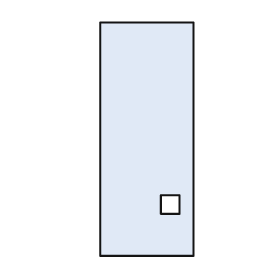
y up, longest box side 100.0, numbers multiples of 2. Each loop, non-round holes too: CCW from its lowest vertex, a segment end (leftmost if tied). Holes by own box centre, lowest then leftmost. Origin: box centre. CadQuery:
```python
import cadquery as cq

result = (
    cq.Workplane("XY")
    .moveTo(-20.0, -50.0)
    .lineTo(20.0, -50.0)
    .lineTo(20.0, 50.0)
    .lineTo(-20.0, 50.0)
    .close()
    .moveTo(6.0, -32.0)
    .lineTo(14.0, -32.0)
    .lineTo(14.0, -24.0)
    .lineTo(6.0, -24.0)
    .close()
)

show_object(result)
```